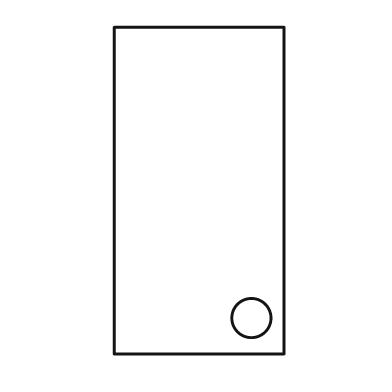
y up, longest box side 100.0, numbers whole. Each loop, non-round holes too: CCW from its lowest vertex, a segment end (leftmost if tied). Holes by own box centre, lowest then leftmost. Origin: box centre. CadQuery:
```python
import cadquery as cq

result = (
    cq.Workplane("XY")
    .moveTo(-26.0, -50.0)
    .lineTo(26.0, -50.0)
    .lineTo(26.0, 50.0)
    .lineTo(-26.0, 50.0)
    .close()
    .moveTo(16.0, -39.0)
    .circle(6.0)
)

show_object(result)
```